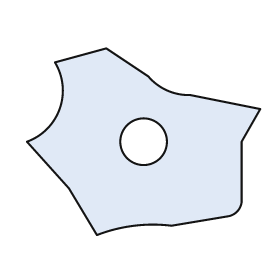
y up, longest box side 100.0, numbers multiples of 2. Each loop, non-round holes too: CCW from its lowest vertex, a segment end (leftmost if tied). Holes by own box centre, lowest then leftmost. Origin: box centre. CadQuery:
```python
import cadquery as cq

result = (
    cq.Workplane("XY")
    .moveTo(-20.0, -40.0)
    .threePointArc((-4.0, -36.0), (12.0, -36.0))
    .lineTo(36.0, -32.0)
    .threePointArc((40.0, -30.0), (42.0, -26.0))
    .lineTo(42.0, 0.0)
    .lineTo(50.0, 14.0)
    .lineTo(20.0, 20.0)
    .threePointArc((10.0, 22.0), (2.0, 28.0))
    .lineTo(-16.0, 40.0)
    .lineTo(-38.0, 34.0)
    .threePointArc((-36.0, 14.0), (-50.0, 0.0))
    .lineTo(-32.0, -20.0)
    .close()
    .moveTo(0.0, 0.0)
    .circle(10.0)
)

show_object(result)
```